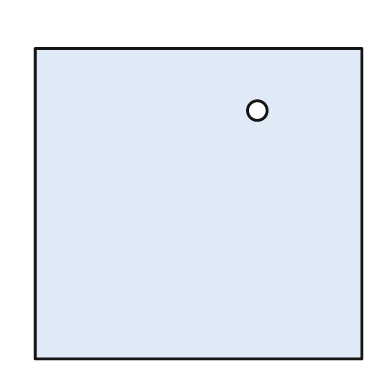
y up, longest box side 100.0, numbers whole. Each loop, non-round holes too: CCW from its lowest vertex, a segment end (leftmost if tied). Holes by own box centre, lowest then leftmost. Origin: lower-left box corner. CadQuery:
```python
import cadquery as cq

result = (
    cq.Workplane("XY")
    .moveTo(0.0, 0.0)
    .lineTo(100.0, 0.0)
    .lineTo(100.0, 95.0)
    .lineTo(0.0, 95.0)
    .close()
    .moveTo(68.0, 76.0)
    .circle(3.0)
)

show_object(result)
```